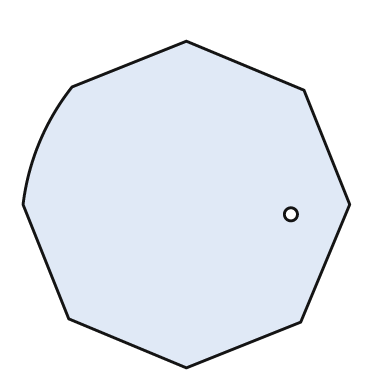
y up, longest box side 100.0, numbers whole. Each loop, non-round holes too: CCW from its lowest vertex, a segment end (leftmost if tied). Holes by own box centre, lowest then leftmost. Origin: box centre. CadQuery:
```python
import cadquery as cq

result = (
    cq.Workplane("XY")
    .moveTo(0.0, -50.0)
    .lineTo(35.0, -36.0)
    .lineTo(50.0, 0.0)
    .lineTo(36.0, 35.0)
    .lineTo(0.0, 50.0)
    .lineTo(-35.0, 36.0)
    .threePointArc((-45.0, 19.0), (-50.0, 0.0))
    .lineTo(-36.0, -35.0)
    .close()
    .moveTo(32.0, -3.0)
    .circle(2.0)
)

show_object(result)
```